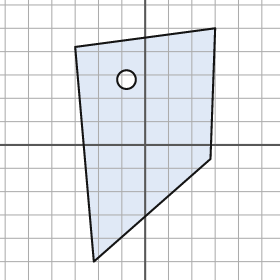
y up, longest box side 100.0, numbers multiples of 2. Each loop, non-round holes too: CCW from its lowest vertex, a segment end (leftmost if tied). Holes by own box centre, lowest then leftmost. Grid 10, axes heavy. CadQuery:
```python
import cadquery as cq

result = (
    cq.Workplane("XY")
    .moveTo(-22.0, -50.0)
    .lineTo(28.0, -6.0)
    .lineTo(30.0, 50.0)
    .lineTo(-30.0, 42.0)
    .close()
    .moveTo(-8.0, 28.0)
    .circle(4.0)
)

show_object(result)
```